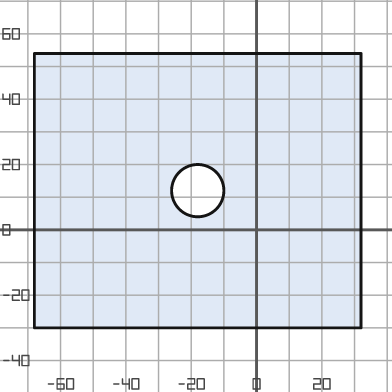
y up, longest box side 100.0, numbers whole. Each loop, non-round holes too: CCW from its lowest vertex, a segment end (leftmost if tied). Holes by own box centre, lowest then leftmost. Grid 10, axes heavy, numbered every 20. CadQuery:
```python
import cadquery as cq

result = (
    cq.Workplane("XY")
    .moveTo(-68.0, -30.0)
    .lineTo(32.0, -30.0)
    .lineTo(32.0, 54.0)
    .lineTo(-68.0, 54.0)
    .close()
    .moveTo(-18.0, 12.0)
    .circle(8.0)
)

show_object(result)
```